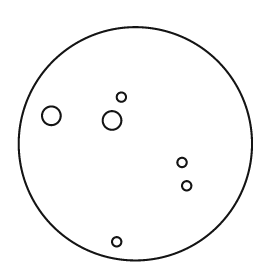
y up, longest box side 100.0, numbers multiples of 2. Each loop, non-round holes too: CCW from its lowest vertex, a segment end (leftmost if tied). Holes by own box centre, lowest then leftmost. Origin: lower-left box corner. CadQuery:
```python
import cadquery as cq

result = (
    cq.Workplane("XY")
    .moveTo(50.0, 50.0)
    .circle(50.0)
    .moveTo(42.0, 8.0)
    .circle(2.0)
    .moveTo(72.0, 32.0)
    .circle(2.0)
    .moveTo(70.0, 42.0)
    .circle(2.0)
    .moveTo(40.0, 60.0)
    .circle(4.0)
    .moveTo(14.0, 62.0)
    .circle(4.0)
    .moveTo(44.0, 70.0)
    .circle(2.0)
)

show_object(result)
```